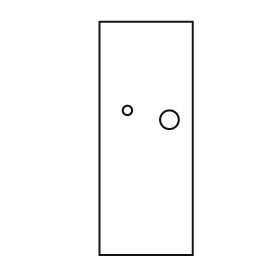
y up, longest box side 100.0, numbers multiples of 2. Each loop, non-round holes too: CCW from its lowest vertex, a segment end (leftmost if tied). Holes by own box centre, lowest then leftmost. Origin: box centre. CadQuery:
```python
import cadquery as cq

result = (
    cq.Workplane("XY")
    .moveTo(-20.0, -50.0)
    .lineTo(20.0, -50.0)
    .lineTo(20.0, 50.0)
    .lineTo(-20.0, 50.0)
    .close()
    .moveTo(10.0, 8.0)
    .circle(4.0)
    .moveTo(-8.0, 12.0)
    .circle(2.0)
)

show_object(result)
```